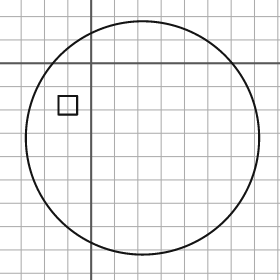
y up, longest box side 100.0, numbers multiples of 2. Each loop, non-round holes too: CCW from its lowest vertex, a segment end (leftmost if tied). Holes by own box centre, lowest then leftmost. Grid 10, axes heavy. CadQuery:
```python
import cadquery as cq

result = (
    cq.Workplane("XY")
    .moveTo(22.0, -32.0)
    .circle(50.0)
    .moveTo(-14.0, -22.0)
    .lineTo(-6.0, -22.0)
    .lineTo(-6.0, -14.0)
    .lineTo(-14.0, -14.0)
    .close()
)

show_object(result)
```